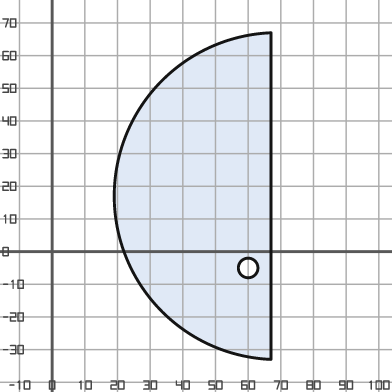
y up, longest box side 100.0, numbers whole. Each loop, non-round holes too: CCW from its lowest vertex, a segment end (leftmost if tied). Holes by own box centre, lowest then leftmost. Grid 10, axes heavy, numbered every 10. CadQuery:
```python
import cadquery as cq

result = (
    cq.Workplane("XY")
    .moveTo(67.0, -33.0)
    .lineTo(67.0, 67.0)
    .threePointArc((19.0, 17.0), (67.0, -33.0))
    .close()
    .moveTo(60.0, -5.0)
    .circle(3.0)
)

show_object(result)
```